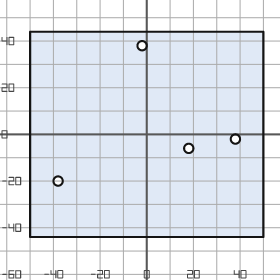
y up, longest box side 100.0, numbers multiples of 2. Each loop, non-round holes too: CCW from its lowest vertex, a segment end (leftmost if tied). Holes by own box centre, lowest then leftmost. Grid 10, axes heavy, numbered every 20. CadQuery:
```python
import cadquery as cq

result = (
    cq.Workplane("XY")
    .moveTo(-50.0, -44.0)
    .lineTo(50.0, -44.0)
    .lineTo(50.0, 44.0)
    .lineTo(-50.0, 44.0)
    .close()
    .moveTo(-38.0, -20.0)
    .circle(2.0)
    .moveTo(18.0, -6.0)
    .circle(2.0)
    .moveTo(38.0, -2.0)
    .circle(2.0)
    .moveTo(-2.0, 38.0)
    .circle(2.0)
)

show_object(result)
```